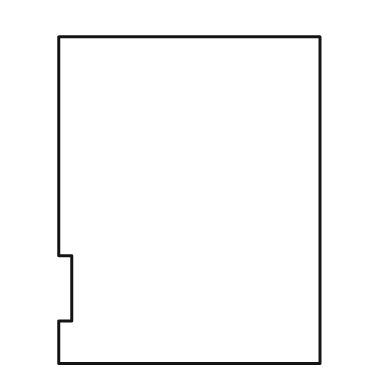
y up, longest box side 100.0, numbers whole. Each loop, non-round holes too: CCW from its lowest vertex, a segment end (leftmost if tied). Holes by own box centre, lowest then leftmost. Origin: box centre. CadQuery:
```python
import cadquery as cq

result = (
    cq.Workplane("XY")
    .moveTo(-40.0, -50.0)
    .lineTo(40.0, -50.0)
    .lineTo(40.0, 50.0)
    .lineTo(-40.0, 50.0)
    .lineTo(-40.0, -17.0)
    .lineTo(-36.0, -17.0)
    .lineTo(-36.0, -37.0)
    .lineTo(-40.0, -37.0)
    .close()
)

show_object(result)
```